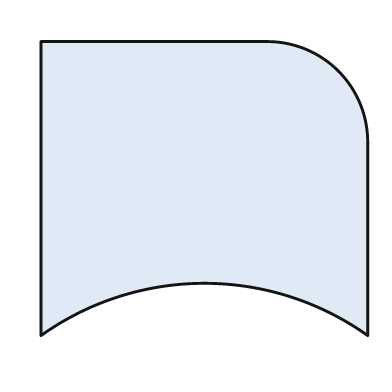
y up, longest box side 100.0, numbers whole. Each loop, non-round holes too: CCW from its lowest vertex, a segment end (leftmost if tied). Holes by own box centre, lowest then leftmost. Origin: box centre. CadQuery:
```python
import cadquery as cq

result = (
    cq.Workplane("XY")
    .moveTo(-50.0, -45.0)
    .threePointArc((0.0, -29.0), (50.0, -45.0))
    .lineTo(50.0, 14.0)
    .threePointArc((41.0, 36.0), (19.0, 45.0))
    .lineTo(-50.0, 45.0)
    .close()
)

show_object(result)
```